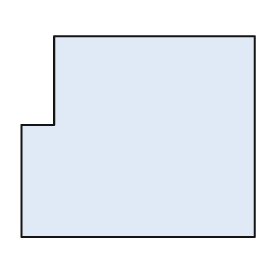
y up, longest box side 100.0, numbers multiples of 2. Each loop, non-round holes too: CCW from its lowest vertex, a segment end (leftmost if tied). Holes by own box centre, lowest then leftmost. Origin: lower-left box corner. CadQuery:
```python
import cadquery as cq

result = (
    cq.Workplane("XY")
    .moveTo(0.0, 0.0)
    .lineTo(100.0, 0.0)
    .lineTo(100.0, 86.0)
    .lineTo(14.0, 86.0)
    .lineTo(14.0, 48.0)
    .lineTo(0.0, 48.0)
    .close()
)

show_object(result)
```